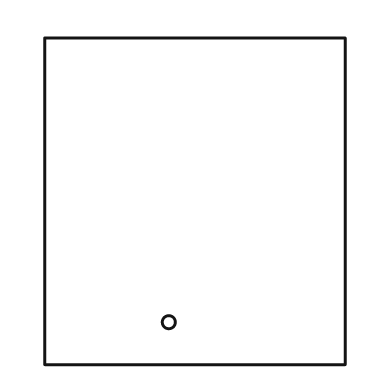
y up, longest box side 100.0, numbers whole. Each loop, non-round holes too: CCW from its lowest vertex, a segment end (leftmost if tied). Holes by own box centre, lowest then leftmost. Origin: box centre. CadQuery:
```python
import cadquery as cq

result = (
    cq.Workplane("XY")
    .moveTo(-46.0, -50.0)
    .lineTo(46.0, -50.0)
    .lineTo(46.0, 50.0)
    .lineTo(-46.0, 50.0)
    .close()
    .moveTo(-8.0, -37.0)
    .circle(2.0)
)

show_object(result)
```